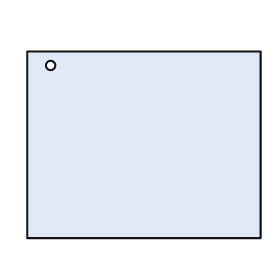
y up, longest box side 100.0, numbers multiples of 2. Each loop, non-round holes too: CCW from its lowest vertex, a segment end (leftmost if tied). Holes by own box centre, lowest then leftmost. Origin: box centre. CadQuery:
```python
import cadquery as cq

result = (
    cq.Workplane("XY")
    .moveTo(-50.0, -40.0)
    .lineTo(50.0, -40.0)
    .lineTo(50.0, 40.0)
    .lineTo(-50.0, 40.0)
    .close()
    .moveTo(-40.0, 34.0)
    .circle(2.0)
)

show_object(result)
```